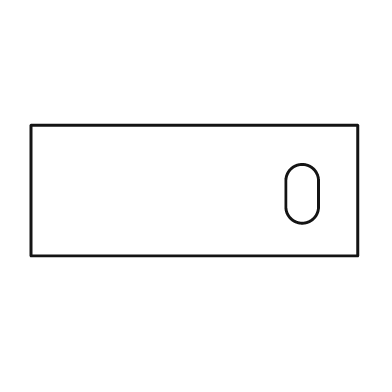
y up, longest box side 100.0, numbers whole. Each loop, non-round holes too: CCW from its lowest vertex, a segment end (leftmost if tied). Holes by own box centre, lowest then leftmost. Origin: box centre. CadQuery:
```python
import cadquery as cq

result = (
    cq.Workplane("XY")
    .moveTo(-50.0, -20.0)
    .lineTo(50.0, -20.0)
    .lineTo(50.0, 20.0)
    .lineTo(-50.0, 20.0)
    .close()
    .moveTo(28.0, -5.0)
    .threePointArc((33.0, -10.0), (38.0, -5.0))
    .lineTo(38.0, 3.0)
    .threePointArc((33.0, 8.0), (28.0, 3.0))
    .close()
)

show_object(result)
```